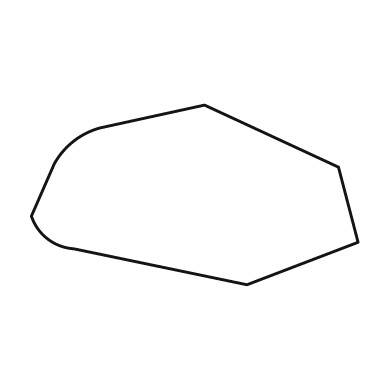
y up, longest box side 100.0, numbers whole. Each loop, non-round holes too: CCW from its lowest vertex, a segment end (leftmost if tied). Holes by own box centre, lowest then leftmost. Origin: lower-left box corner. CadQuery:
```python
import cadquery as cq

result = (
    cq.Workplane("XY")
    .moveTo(66.0, 0.0)
    .lineTo(100.0, 13.0)
    .lineTo(94.0, 36.0)
    .lineTo(53.0, 55.0)
    .lineTo(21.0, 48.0)
    .threePointArc((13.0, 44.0), (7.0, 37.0))
    .lineTo(0.0, 21.0)
    .threePointArc((5.0, 14.0), (13.0, 11.0))
    .close()
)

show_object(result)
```